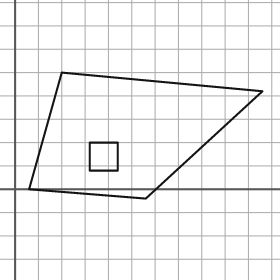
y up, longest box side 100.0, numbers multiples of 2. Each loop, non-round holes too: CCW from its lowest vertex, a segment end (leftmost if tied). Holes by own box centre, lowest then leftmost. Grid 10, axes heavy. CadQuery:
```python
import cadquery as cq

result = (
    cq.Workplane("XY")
    .moveTo(56.0, -4.0)
    .lineTo(106.0, 42.0)
    .lineTo(20.0, 50.0)
    .lineTo(6.0, 0.0)
    .close()
    .moveTo(32.0, 8.0)
    .lineTo(44.0, 8.0)
    .lineTo(44.0, 20.0)
    .lineTo(32.0, 20.0)
    .close()
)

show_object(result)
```